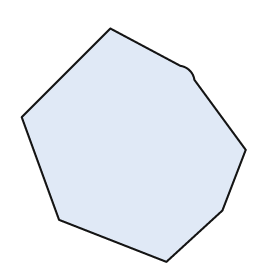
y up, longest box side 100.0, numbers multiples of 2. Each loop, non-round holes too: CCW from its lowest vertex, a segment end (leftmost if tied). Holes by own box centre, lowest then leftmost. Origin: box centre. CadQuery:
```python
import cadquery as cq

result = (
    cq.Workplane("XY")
    .moveTo(14.0, -50.0)
    .lineTo(38.0, -28.0)
    .lineTo(48.0, -2.0)
    .lineTo(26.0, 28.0)
    .threePointArc((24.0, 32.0), (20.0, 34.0))
    .lineTo(-10.0, 50.0)
    .lineTo(-48.0, 12.0)
    .lineTo(-32.0, -32.0)
    .close()
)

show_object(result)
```